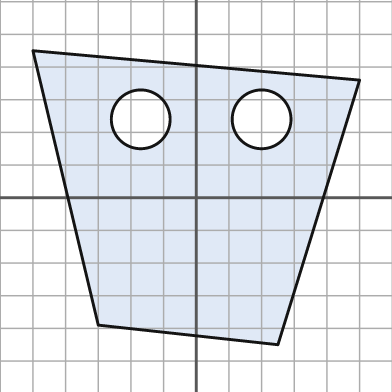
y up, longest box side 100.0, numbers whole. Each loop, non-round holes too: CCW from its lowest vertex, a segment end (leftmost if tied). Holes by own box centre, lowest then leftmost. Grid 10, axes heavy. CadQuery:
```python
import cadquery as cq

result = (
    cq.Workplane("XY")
    .moveTo(25.0, -45.0)
    .lineTo(50.0, 36.0)
    .lineTo(-50.0, 45.0)
    .lineTo(-30.0, -39.0)
    .close()
    .moveTo(-17.0, 24.0)
    .circle(9.0)
    .moveTo(20.0, 24.0)
    .circle(9.0)
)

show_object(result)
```